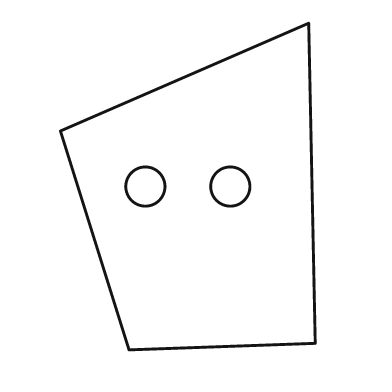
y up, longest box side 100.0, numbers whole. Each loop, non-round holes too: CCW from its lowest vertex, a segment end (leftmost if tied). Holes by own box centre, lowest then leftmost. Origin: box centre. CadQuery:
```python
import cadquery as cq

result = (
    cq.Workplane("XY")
    .moveTo(-18.0, -50.0)
    .lineTo(39.0, -48.0)
    .lineTo(37.0, 50.0)
    .lineTo(-39.0, 17.0)
    .close()
    .moveTo(-13.0, 0.0)
    .circle(6.0)
    .moveTo(13.0, 0.0)
    .circle(6.0)
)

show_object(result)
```